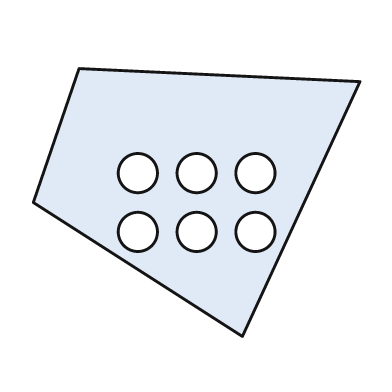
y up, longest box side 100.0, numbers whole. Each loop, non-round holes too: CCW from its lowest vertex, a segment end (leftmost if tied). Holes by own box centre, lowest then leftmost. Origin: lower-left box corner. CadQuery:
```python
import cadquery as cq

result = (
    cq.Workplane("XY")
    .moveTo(64.0, 0.0)
    .lineTo(100.0, 78.0)
    .lineTo(14.0, 82.0)
    .lineTo(0.0, 41.0)
    .close()
    .moveTo(32.0, 32.0)
    .circle(6.0)
    .moveTo(50.0, 32.0)
    .circle(6.0)
    .moveTo(68.0, 32.0)
    .circle(6.0)
    .moveTo(32.0, 50.0)
    .circle(6.0)
    .moveTo(50.0, 50.0)
    .circle(6.0)
    .moveTo(68.0, 50.0)
    .circle(6.0)
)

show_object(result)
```